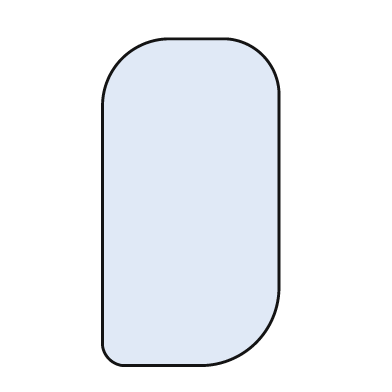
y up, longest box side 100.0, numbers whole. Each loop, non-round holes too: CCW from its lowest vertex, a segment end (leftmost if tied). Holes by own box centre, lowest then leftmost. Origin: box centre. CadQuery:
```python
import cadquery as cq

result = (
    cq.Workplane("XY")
    .moveTo(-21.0, -50.0)
    .lineTo(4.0, -50.0)
    .threePointArc((20.0, -43.0), (27.0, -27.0))
    .lineTo(27.0, 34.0)
    .threePointArc((22.0, 45.0), (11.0, 50.0))
    .lineTo(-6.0, 50.0)
    .threePointArc((-21.0, 44.0), (-27.0, 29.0))
    .lineTo(-27.0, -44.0)
    .threePointArc((-25.0, -48.0), (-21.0, -50.0))
    .close()
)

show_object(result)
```